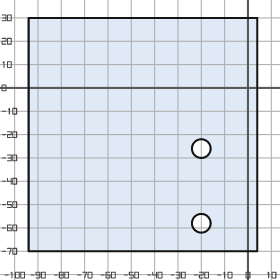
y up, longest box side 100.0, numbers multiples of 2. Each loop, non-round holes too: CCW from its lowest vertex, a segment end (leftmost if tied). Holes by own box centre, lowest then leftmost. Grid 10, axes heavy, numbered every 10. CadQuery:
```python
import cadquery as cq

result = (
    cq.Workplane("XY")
    .moveTo(-94.0, -70.0)
    .lineTo(4.0, -70.0)
    .lineTo(4.0, 30.0)
    .lineTo(-94.0, 30.0)
    .close()
    .moveTo(-20.0, -58.0)
    .circle(4.0)
    .moveTo(-20.0, -26.0)
    .circle(4.0)
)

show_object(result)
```